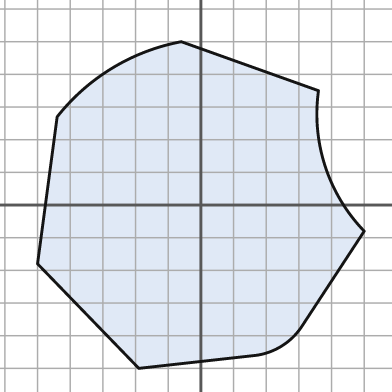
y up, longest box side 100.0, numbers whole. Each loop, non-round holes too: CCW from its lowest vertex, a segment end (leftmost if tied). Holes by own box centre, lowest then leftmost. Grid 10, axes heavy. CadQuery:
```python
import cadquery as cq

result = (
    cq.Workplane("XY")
    .moveTo(-19.0, -50.0)
    .lineTo(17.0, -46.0)
    .threePointArc((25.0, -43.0), (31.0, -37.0))
    .lineTo(50.0, -8.0)
    .threePointArc((38.0, 12.0), (36.0, 35.0))
    .lineTo(-6.0, 50.0)
    .threePointArc((-27.0, 42.0), (-44.0, 27.0))
    .lineTo(-50.0, -18.0)
    .close()
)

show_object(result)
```